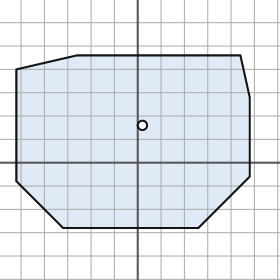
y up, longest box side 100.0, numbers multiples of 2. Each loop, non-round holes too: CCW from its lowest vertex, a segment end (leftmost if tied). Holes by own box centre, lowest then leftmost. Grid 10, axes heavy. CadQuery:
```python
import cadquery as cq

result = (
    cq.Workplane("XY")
    .moveTo(-32.0, -28.0)
    .lineTo(26.0, -28.0)
    .lineTo(48.0, -6.0)
    .lineTo(48.0, 28.0)
    .lineTo(44.0, 46.0)
    .lineTo(-26.0, 46.0)
    .lineTo(-52.0, 40.0)
    .lineTo(-52.0, -8.0)
    .close()
    .moveTo(2.0, 16.0)
    .circle(2.0)
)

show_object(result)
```